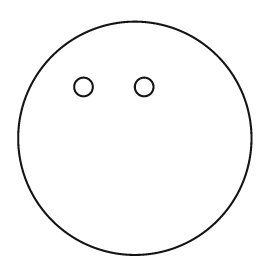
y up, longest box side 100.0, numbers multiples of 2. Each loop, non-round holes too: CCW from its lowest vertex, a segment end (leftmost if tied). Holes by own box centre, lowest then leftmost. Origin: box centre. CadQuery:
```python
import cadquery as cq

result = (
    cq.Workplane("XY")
    .moveTo(0.0, 0.0)
    .circle(50.0)
    .moveTo(-22.0, 22.0)
    .circle(4.0)
    .moveTo(4.0, 22.0)
    .circle(4.0)
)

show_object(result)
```